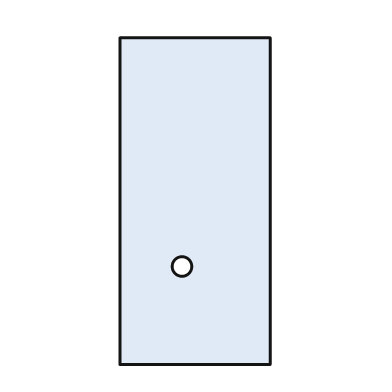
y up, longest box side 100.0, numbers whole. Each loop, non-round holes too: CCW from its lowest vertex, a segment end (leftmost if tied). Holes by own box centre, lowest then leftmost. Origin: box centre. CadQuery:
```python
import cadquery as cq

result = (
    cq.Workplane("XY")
    .moveTo(-23.0, -50.0)
    .lineTo(23.0, -50.0)
    .lineTo(23.0, 50.0)
    .lineTo(-23.0, 50.0)
    .close()
    .moveTo(-4.0, -20.0)
    .circle(3.0)
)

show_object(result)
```